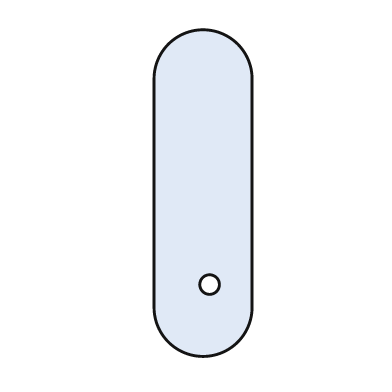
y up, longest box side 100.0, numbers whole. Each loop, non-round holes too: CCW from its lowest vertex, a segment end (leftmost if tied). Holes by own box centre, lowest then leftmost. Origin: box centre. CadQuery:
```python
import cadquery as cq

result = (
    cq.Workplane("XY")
    .moveTo(-15.0, -35.0)
    .threePointArc((0.0, -50.0), (15.0, -35.0))
    .lineTo(15.0, 35.0)
    .threePointArc((0.0, 50.0), (-15.0, 35.0))
    .close()
    .moveTo(2.0, -28.0)
    .circle(3.0)
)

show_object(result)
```